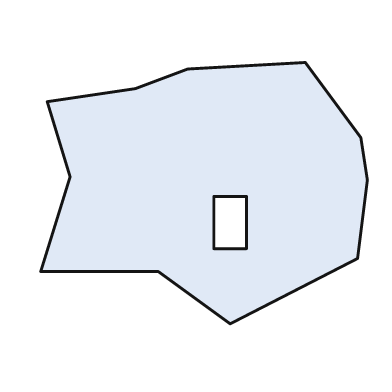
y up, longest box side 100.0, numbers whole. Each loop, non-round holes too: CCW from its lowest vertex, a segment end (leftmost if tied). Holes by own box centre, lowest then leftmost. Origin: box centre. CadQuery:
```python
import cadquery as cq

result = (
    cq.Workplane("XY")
    .moveTo(8.0, -40.0)
    .lineTo(47.0, -20.0)
    .lineTo(50.0, 4.0)
    .lineTo(48.0, 17.0)
    .lineTo(31.0, 40.0)
    .lineTo(-5.0, 38.0)
    .lineTo(-21.0, 32.0)
    .lineTo(-48.0, 28.0)
    .lineTo(-41.0, 5.0)
    .lineTo(-50.0, -24.0)
    .lineTo(-14.0, -24.0)
    .close()
    .moveTo(3.0, -17.0)
    .lineTo(13.0, -17.0)
    .lineTo(13.0, -1.0)
    .lineTo(3.0, -1.0)
    .close()
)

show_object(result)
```